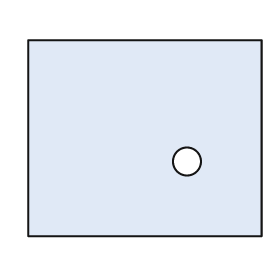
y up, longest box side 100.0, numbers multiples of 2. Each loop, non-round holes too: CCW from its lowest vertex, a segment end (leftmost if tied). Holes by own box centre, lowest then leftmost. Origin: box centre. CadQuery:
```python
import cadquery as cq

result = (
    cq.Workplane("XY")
    .moveTo(-50.0, -42.0)
    .lineTo(50.0, -42.0)
    .lineTo(50.0, 42.0)
    .lineTo(-50.0, 42.0)
    .close()
    .moveTo(18.0, -10.0)
    .circle(6.0)
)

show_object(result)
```